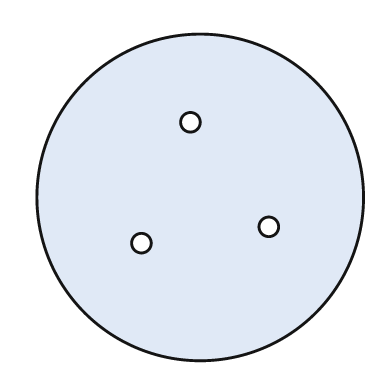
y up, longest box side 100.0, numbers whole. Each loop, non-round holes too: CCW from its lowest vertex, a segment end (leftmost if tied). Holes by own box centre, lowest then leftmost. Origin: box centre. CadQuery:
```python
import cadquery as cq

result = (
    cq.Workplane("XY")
    .moveTo(0.0, 0.0)
    .circle(50.0)
    .moveTo(-18.0, -14.0)
    .circle(3.0)
    .moveTo(21.0, -9.0)
    .circle(3.0)
    .moveTo(-3.0, 23.0)
    .circle(3.0)
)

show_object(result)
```